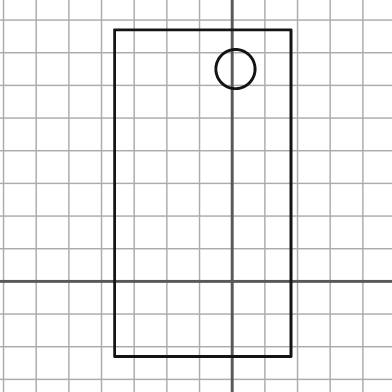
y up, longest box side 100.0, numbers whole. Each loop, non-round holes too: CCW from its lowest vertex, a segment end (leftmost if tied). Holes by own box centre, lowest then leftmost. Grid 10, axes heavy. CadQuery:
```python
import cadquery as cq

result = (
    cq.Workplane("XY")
    .moveTo(-36.0, -23.0)
    .lineTo(18.0, -23.0)
    .lineTo(18.0, 77.0)
    .lineTo(-36.0, 77.0)
    .close()
    .moveTo(1.0, 65.0)
    .circle(6.0)
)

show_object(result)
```